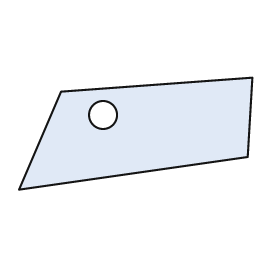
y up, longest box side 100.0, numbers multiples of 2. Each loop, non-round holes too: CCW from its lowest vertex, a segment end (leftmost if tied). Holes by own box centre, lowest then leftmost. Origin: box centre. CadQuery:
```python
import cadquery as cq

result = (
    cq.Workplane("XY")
    .moveTo(-50.0, -24.0)
    .lineTo(48.0, -10.0)
    .lineTo(50.0, 24.0)
    .lineTo(-32.0, 18.0)
    .close()
    .moveTo(-14.0, 8.0)
    .circle(6.0)
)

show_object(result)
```